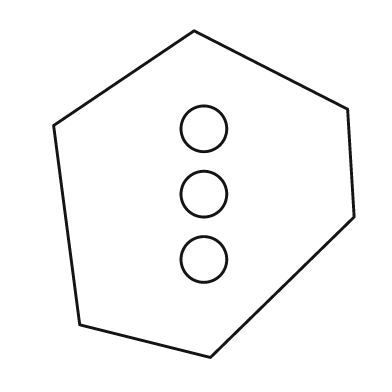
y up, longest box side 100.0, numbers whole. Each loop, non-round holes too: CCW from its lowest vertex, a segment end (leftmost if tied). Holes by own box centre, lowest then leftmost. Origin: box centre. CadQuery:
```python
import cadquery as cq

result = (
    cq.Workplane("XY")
    .moveTo(2.0, -50.0)
    .lineTo(46.0, -7.0)
    .lineTo(44.0, 26.0)
    .lineTo(-3.0, 50.0)
    .lineTo(-46.0, 21.0)
    .lineTo(-38.0, -40.0)
    .close()
    .moveTo(0.0, -20.0)
    .circle(7.0)
    .moveTo(0.0, 0.0)
    .circle(7.0)
    .moveTo(0.0, 20.0)
    .circle(7.0)
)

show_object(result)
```